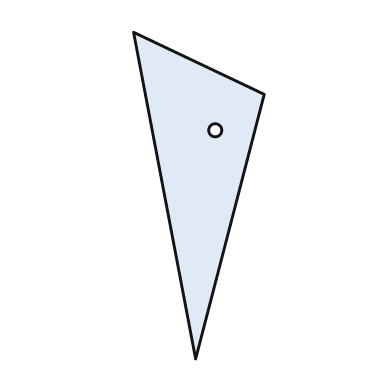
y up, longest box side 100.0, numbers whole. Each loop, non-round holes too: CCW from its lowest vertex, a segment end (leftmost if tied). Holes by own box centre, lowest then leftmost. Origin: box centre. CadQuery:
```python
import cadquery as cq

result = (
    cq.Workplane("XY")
    .moveTo(-1.0, -50.0)
    .lineTo(20.0, 31.0)
    .lineTo(-20.0, 50.0)
    .close()
    .moveTo(5.0, 20.0)
    .circle(2.0)
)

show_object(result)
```